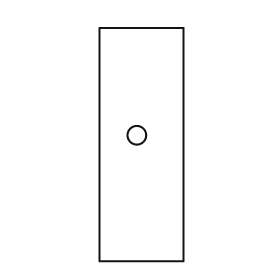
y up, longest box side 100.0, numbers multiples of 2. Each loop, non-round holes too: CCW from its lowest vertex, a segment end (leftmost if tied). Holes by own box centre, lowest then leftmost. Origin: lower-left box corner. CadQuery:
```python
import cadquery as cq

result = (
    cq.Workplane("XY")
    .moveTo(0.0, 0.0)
    .lineTo(36.0, 0.0)
    .lineTo(36.0, 100.0)
    .lineTo(0.0, 100.0)
    .close()
    .moveTo(16.0, 54.0)
    .circle(4.0)
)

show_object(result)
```